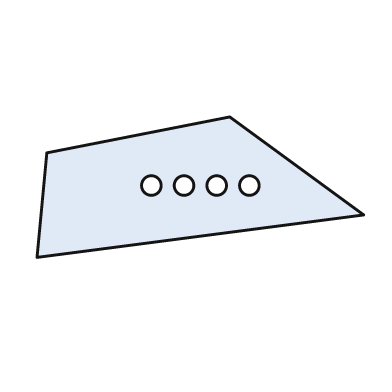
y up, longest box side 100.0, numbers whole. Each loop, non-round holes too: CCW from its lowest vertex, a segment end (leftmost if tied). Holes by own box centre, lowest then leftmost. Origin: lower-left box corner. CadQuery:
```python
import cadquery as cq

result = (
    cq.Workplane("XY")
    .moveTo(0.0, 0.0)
    .lineTo(100.0, 13.0)
    .lineTo(59.0, 43.0)
    .lineTo(3.0, 32.0)
    .close()
    .moveTo(35.0, 22.0)
    .circle(3.0)
    .moveTo(45.0, 22.0)
    .circle(3.0)
    .moveTo(55.0, 22.0)
    .circle(3.0)
    .moveTo(65.0, 22.0)
    .circle(3.0)
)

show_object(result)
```